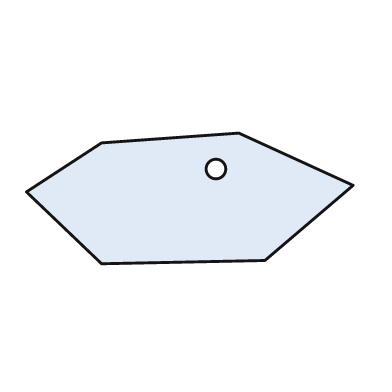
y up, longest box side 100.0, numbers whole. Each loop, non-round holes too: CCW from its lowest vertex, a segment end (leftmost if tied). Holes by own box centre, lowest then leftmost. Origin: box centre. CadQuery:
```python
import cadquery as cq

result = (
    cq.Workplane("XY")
    .moveTo(-27.0, -20.0)
    .lineTo(23.0, -19.0)
    .lineTo(50.0, 4.0)
    .lineTo(15.0, 20.0)
    .lineTo(-27.0, 17.0)
    .lineTo(-50.0, 2.0)
    .close()
    .moveTo(8.0, 9.0)
    .circle(3.0)
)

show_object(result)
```